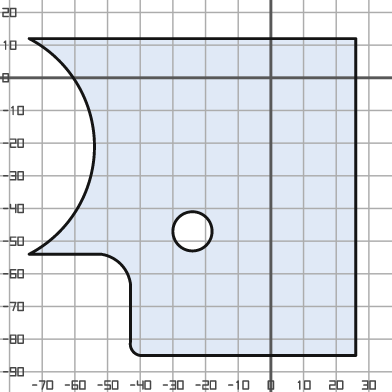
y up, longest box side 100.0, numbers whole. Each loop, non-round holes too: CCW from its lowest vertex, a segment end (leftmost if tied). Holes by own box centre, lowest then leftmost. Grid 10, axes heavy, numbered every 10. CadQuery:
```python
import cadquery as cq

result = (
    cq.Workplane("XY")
    .moveTo(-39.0, -85.0)
    .lineTo(26.0, -85.0)
    .lineTo(26.0, 12.0)
    .lineTo(-74.0, 12.0)
    .threePointArc((-54.0, -21.0), (-74.0, -54.0))
    .lineTo(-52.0, -54.0)
    .threePointArc((-46.0, -57.0), (-43.0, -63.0))
    .lineTo(-43.0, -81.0)
    .threePointArc((-42.0, -84.0), (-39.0, -85.0))
    .close()
    .moveTo(-24.0, -47.0)
    .circle(6.0)
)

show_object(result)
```